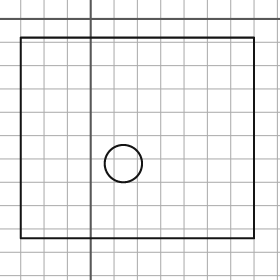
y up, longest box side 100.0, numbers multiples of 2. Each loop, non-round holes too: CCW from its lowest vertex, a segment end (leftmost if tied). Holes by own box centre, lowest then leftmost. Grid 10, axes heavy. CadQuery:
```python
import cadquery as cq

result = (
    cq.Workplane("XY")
    .moveTo(-30.0, -94.0)
    .lineTo(70.0, -94.0)
    .lineTo(70.0, -8.0)
    .lineTo(-30.0, -8.0)
    .close()
    .moveTo(14.0, -62.0)
    .circle(8.0)
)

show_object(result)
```